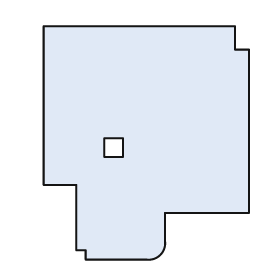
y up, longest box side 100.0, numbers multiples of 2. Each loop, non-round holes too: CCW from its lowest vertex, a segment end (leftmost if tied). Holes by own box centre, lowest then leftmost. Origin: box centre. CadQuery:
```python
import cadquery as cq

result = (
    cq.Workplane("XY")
    .moveTo(-26.0, -50.0)
    .lineTo(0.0, -50.0)
    .threePointArc((6.0, -48.0), (8.0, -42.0))
    .lineTo(8.0, -30.0)
    .lineTo(44.0, -30.0)
    .lineTo(44.0, 40.0)
    .lineTo(38.0, 40.0)
    .lineTo(38.0, 50.0)
    .lineTo(-44.0, 50.0)
    .lineTo(-44.0, -18.0)
    .lineTo(-30.0, -18.0)
    .lineTo(-30.0, -46.0)
    .lineTo(-26.0, -46.0)
    .close()
    .moveTo(-18.0, -6.0)
    .lineTo(-10.0, -6.0)
    .lineTo(-10.0, 2.0)
    .lineTo(-18.0, 2.0)
    .close()
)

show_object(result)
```